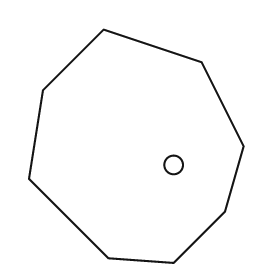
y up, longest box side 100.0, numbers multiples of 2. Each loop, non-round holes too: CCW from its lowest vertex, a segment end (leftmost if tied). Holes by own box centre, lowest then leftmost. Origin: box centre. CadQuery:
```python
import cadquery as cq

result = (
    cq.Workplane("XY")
    .moveTo(16.0, -50.0)
    .lineTo(38.0, -28.0)
    .lineTo(46.0, 0.0)
    .lineTo(28.0, 36.0)
    .lineTo(-14.0, 50.0)
    .lineTo(-40.0, 24.0)
    .lineTo(-46.0, -14.0)
    .lineTo(-12.0, -48.0)
    .close()
    .moveTo(16.0, -8.0)
    .circle(4.0)
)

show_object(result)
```